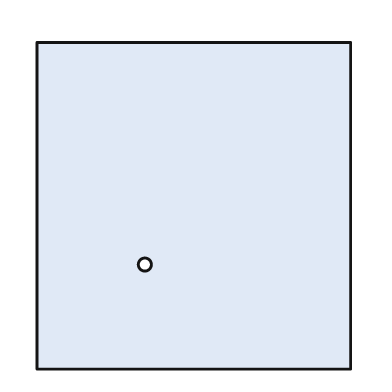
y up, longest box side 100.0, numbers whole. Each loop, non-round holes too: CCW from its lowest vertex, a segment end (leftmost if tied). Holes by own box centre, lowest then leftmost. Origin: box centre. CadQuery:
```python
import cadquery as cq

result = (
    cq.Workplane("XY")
    .moveTo(-48.0, -50.0)
    .lineTo(48.0, -50.0)
    .lineTo(48.0, 50.0)
    .lineTo(-48.0, 50.0)
    .close()
    .moveTo(-15.0, -18.0)
    .circle(2.0)
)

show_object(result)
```